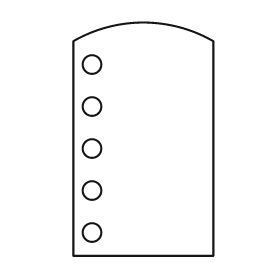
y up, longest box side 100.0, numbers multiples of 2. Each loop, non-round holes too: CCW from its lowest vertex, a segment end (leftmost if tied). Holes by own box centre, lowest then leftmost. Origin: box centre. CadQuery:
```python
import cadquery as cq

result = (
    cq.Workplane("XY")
    .moveTo(-30.0, -50.0)
    .lineTo(30.0, -50.0)
    .lineTo(30.0, 42.0)
    .threePointArc((0.0, 50.0), (-30.0, 42.0))
    .close()
    .moveTo(-22.0, -40.0)
    .circle(4.0)
    .moveTo(-22.0, -22.0)
    .circle(4.0)
    .moveTo(-22.0, -4.0)
    .circle(4.0)
    .moveTo(-22.0, 14.0)
    .circle(4.0)
    .moveTo(-22.0, 32.0)
    .circle(4.0)
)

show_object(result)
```